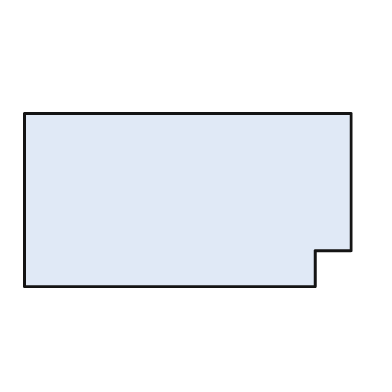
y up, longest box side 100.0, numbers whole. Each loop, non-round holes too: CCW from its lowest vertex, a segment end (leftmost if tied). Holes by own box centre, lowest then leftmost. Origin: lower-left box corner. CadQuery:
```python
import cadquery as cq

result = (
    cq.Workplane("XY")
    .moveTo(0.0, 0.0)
    .lineTo(89.0, 0.0)
    .lineTo(89.0, 11.0)
    .lineTo(100.0, 11.0)
    .lineTo(100.0, 53.0)
    .lineTo(0.0, 53.0)
    .close()
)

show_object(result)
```